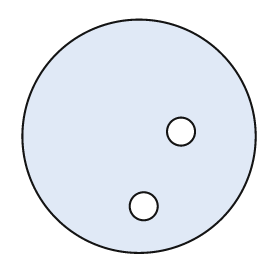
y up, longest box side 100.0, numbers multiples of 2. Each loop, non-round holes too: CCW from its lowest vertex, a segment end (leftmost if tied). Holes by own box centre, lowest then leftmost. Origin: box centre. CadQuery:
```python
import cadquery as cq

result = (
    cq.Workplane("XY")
    .moveTo(0.0, 0.0)
    .circle(50.0)
    .moveTo(2.0, -30.0)
    .circle(6.0)
    .moveTo(18.0, 2.0)
    .circle(6.0)
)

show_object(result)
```